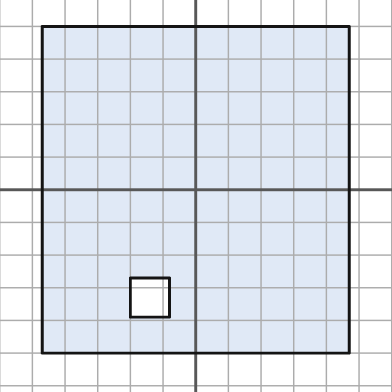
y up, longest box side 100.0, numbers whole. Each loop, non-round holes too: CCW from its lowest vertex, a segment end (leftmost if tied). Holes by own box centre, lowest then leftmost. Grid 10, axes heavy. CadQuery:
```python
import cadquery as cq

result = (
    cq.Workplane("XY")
    .moveTo(-47.0, -50.0)
    .lineTo(47.0, -50.0)
    .lineTo(47.0, 50.0)
    .lineTo(-47.0, 50.0)
    .close()
    .moveTo(-20.0, -39.0)
    .lineTo(-8.0, -39.0)
    .lineTo(-8.0, -27.0)
    .lineTo(-20.0, -27.0)
    .close()
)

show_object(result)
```